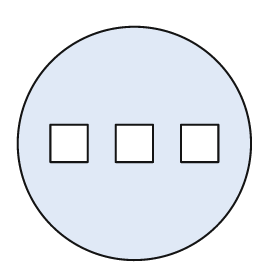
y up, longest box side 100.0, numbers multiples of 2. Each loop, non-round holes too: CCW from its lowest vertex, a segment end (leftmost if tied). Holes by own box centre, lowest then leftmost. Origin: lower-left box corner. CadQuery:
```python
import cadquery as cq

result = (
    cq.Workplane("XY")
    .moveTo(50.0, 50.0)
    .circle(50.0)
    .moveTo(14.0, 42.0)
    .lineTo(30.0, 42.0)
    .lineTo(30.0, 58.0)
    .lineTo(14.0, 58.0)
    .close()
    .moveTo(42.0, 42.0)
    .lineTo(58.0, 42.0)
    .lineTo(58.0, 58.0)
    .lineTo(42.0, 58.0)
    .close()
    .moveTo(70.0, 42.0)
    .lineTo(86.0, 42.0)
    .lineTo(86.0, 58.0)
    .lineTo(70.0, 58.0)
    .close()
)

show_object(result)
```